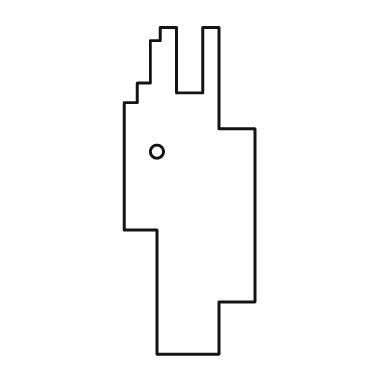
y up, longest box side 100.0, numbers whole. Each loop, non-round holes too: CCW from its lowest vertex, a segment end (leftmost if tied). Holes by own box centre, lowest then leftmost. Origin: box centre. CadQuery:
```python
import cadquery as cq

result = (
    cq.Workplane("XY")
    .moveTo(-10.0, -50.0)
    .lineTo(9.0, -50.0)
    .lineTo(9.0, -34.0)
    .lineTo(20.0, -34.0)
    .lineTo(20.0, 19.0)
    .lineTo(9.0, 19.0)
    .lineTo(9.0, 50.0)
    .lineTo(4.0, 50.0)
    .lineTo(4.0, 30.0)
    .lineTo(-4.0, 30.0)
    .lineTo(-4.0, 50.0)
    .lineTo(-9.0, 50.0)
    .lineTo(-9.0, 46.0)
    .lineTo(-12.0, 46.0)
    .lineTo(-12.0, 33.0)
    .lineTo(-16.0, 33.0)
    .lineTo(-16.0, 27.0)
    .lineTo(-20.0, 27.0)
    .lineTo(-20.0, -12.0)
    .lineTo(-10.0, -12.0)
    .close()
    .moveTo(-10.0, 12.0)
    .circle(2.0)
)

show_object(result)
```